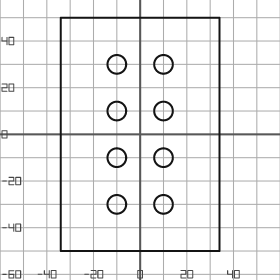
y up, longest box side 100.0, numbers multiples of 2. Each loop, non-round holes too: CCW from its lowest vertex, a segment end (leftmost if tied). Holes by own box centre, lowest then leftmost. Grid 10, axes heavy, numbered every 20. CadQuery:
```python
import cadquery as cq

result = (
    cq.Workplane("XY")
    .moveTo(-34.0, -50.0)
    .lineTo(34.0, -50.0)
    .lineTo(34.0, 50.0)
    .lineTo(-34.0, 50.0)
    .close()
    .moveTo(-10.0, -30.0)
    .circle(4.0)
    .moveTo(10.0, -30.0)
    .circle(4.0)
    .moveTo(-10.0, -10.0)
    .circle(4.0)
    .moveTo(10.0, -10.0)
    .circle(4.0)
    .moveTo(-10.0, 10.0)
    .circle(4.0)
    .moveTo(10.0, 10.0)
    .circle(4.0)
    .moveTo(-10.0, 30.0)
    .circle(4.0)
    .moveTo(10.0, 30.0)
    .circle(4.0)
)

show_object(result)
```